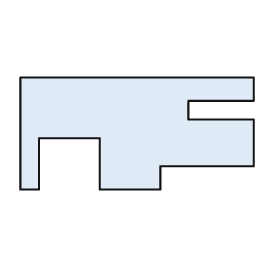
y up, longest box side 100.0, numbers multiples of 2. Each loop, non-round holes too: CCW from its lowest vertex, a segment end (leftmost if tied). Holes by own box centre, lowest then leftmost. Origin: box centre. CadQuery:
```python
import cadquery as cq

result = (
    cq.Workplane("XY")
    .moveTo(-50.0, -24.0)
    .lineTo(-42.0, -24.0)
    .lineTo(-42.0, -2.0)
    .lineTo(-16.0, -2.0)
    .lineTo(-16.0, -24.0)
    .lineTo(10.0, -24.0)
    .lineTo(10.0, -14.0)
    .lineTo(50.0, -14.0)
    .lineTo(50.0, 6.0)
    .lineTo(22.0, 6.0)
    .lineTo(22.0, 14.0)
    .lineTo(50.0, 14.0)
    .lineTo(50.0, 24.0)
    .lineTo(-50.0, 24.0)
    .close()
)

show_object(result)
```